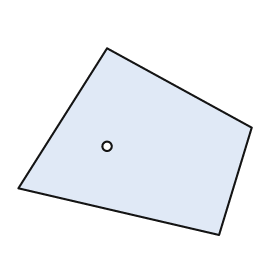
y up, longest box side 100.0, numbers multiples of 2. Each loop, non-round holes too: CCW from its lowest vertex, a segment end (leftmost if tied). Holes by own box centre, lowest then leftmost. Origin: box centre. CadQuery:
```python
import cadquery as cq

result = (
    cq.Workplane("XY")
    .moveTo(36.0, -40.0)
    .lineTo(50.0, 6.0)
    .lineTo(-12.0, 40.0)
    .lineTo(-50.0, -20.0)
    .close()
    .moveTo(-12.0, -2.0)
    .circle(2.0)
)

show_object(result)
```